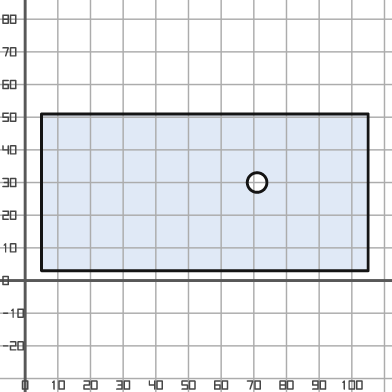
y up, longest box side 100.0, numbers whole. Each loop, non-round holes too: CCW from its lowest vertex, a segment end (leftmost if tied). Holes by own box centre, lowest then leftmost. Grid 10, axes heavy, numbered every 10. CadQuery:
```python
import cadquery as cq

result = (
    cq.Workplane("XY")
    .moveTo(5.0, 3.0)
    .lineTo(105.0, 3.0)
    .lineTo(105.0, 51.0)
    .lineTo(5.0, 51.0)
    .close()
    .moveTo(71.0, 30.0)
    .circle(3.0)
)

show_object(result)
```